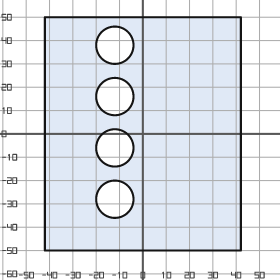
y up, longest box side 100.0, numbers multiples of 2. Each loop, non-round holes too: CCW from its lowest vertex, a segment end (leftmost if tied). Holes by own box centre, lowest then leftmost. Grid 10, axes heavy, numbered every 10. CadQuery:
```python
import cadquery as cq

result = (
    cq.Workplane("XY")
    .moveTo(-42.0, -50.0)
    .lineTo(42.0, -50.0)
    .lineTo(42.0, 50.0)
    .lineTo(-42.0, 50.0)
    .close()
    .moveTo(-12.0, -28.0)
    .circle(8.0)
    .moveTo(-12.0, -6.0)
    .circle(8.0)
    .moveTo(-12.0, 16.0)
    .circle(8.0)
    .moveTo(-12.0, 38.0)
    .circle(8.0)
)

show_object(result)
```